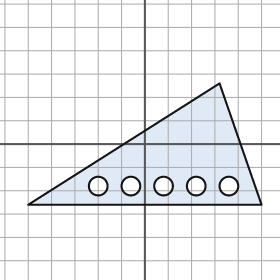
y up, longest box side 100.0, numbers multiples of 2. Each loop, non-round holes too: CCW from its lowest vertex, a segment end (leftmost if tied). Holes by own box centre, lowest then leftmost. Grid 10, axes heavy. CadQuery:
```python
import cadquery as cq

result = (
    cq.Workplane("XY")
    .moveTo(-50.0, -26.0)
    .lineTo(50.0, -26.0)
    .lineTo(32.0, 26.0)
    .close()
    .moveTo(-20.0, -18.0)
    .circle(4.0)
    .moveTo(-6.0, -18.0)
    .circle(4.0)
    .moveTo(8.0, -18.0)
    .circle(4.0)
    .moveTo(22.0, -18.0)
    .circle(4.0)
    .moveTo(36.0, -18.0)
    .circle(4.0)
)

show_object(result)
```